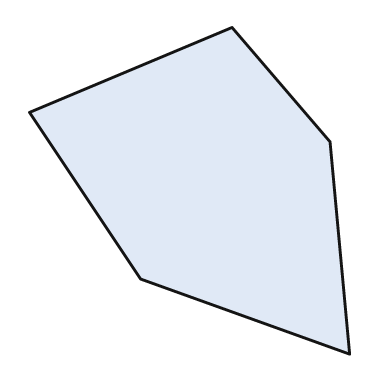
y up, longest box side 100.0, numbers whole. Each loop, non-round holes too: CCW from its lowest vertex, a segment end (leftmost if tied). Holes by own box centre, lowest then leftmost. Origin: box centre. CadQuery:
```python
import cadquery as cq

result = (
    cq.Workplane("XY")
    .moveTo(49.0, -50.0)
    .lineTo(43.0, 15.0)
    .lineTo(13.0, 50.0)
    .lineTo(-49.0, 24.0)
    .lineTo(-15.0, -27.0)
    .close()
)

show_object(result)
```